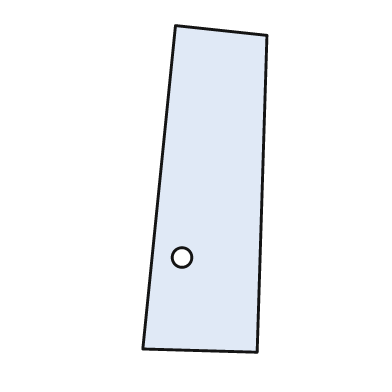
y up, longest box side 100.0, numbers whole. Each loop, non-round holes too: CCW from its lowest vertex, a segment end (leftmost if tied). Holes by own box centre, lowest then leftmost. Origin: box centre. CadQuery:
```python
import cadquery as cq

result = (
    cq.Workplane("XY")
    .moveTo(16.0, -50.0)
    .lineTo(19.0, 47.0)
    .lineTo(-9.0, 50.0)
    .lineTo(-19.0, -49.0)
    .close()
    .moveTo(-7.0, -21.0)
    .circle(3.0)
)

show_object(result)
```